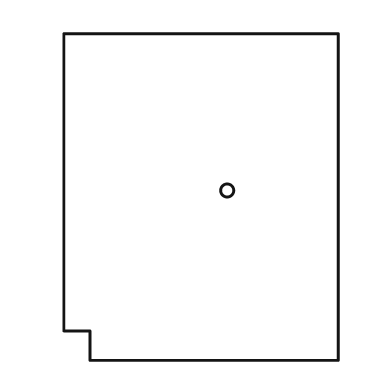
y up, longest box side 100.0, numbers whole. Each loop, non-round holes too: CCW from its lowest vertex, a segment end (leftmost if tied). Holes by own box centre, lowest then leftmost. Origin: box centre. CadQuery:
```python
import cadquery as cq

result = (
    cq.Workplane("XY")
    .moveTo(-34.0, -50.0)
    .lineTo(42.0, -50.0)
    .lineTo(42.0, 50.0)
    .lineTo(-42.0, 50.0)
    .lineTo(-42.0, -41.0)
    .lineTo(-34.0, -41.0)
    .close()
    .moveTo(8.0, 2.0)
    .circle(2.0)
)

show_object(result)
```